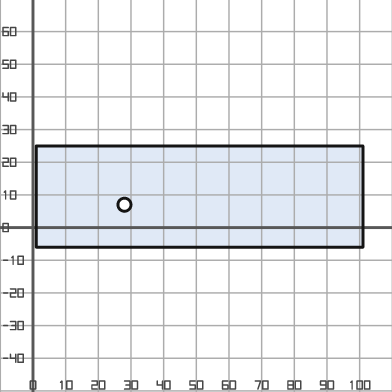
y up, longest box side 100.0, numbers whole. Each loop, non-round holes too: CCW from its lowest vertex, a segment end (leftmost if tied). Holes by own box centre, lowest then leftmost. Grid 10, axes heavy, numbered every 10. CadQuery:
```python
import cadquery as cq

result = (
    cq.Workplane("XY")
    .moveTo(1.0, -6.0)
    .lineTo(101.0, -6.0)
    .lineTo(101.0, 25.0)
    .lineTo(1.0, 25.0)
    .close()
    .moveTo(28.0, 7.0)
    .circle(2.0)
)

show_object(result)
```